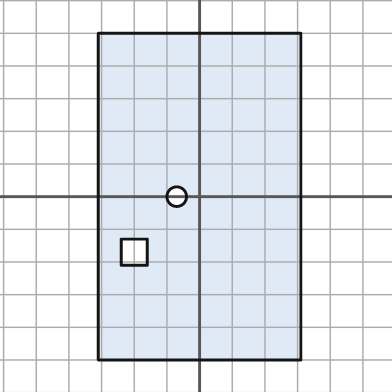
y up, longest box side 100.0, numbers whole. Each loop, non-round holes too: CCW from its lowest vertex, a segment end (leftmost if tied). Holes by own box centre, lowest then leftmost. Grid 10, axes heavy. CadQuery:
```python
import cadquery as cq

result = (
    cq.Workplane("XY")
    .moveTo(-31.0, -50.0)
    .lineTo(31.0, -50.0)
    .lineTo(31.0, 50.0)
    .lineTo(-31.0, 50.0)
    .close()
    .moveTo(-24.0, -21.0)
    .lineTo(-16.0, -21.0)
    .lineTo(-16.0, -13.0)
    .lineTo(-24.0, -13.0)
    .close()
    .moveTo(-7.0, 0.0)
    .circle(3.0)
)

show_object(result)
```